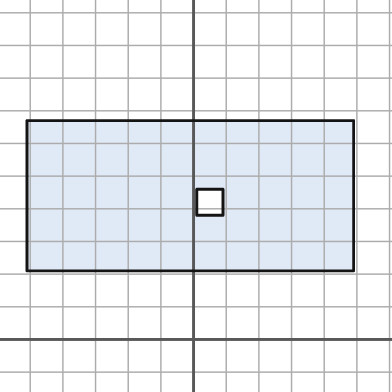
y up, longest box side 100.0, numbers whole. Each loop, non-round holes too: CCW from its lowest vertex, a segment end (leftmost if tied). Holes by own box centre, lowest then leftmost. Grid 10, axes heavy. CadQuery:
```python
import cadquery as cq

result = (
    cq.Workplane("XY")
    .moveTo(-51.0, 21.0)
    .lineTo(49.0, 21.0)
    .lineTo(49.0, 67.0)
    .lineTo(-51.0, 67.0)
    .close()
    .moveTo(1.0, 38.0)
    .lineTo(9.0, 38.0)
    .lineTo(9.0, 46.0)
    .lineTo(1.0, 46.0)
    .close()
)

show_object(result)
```